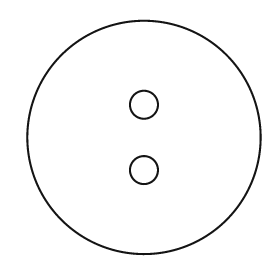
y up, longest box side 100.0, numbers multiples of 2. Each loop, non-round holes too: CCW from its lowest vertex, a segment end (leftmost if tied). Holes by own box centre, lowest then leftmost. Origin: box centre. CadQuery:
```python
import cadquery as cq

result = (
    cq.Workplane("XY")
    .moveTo(0.0, 0.0)
    .circle(50.0)
    .moveTo(0.0, -14.0)
    .circle(6.0)
    .moveTo(0.0, 14.0)
    .circle(6.0)
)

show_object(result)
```